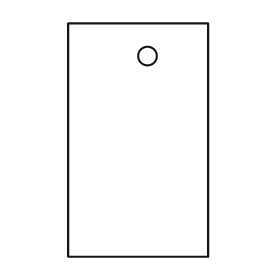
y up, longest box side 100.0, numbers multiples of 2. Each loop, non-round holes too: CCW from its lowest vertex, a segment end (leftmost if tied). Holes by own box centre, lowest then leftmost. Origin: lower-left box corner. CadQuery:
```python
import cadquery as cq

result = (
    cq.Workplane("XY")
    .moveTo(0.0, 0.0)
    .lineTo(60.0, 0.0)
    .lineTo(60.0, 100.0)
    .lineTo(0.0, 100.0)
    .close()
    .moveTo(34.0, 86.0)
    .circle(4.0)
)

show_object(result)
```